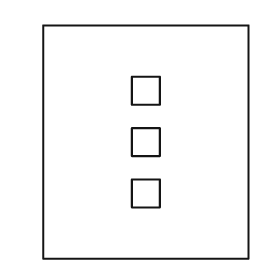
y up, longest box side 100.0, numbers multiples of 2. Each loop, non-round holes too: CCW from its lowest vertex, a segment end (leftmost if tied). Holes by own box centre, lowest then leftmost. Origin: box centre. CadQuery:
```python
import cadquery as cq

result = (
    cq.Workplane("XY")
    .moveTo(-44.0, -50.0)
    .lineTo(44.0, -50.0)
    .lineTo(44.0, 50.0)
    .lineTo(-44.0, 50.0)
    .close()
    .moveTo(-6.0, -28.0)
    .lineTo(6.0, -28.0)
    .lineTo(6.0, -16.0)
    .lineTo(-6.0, -16.0)
    .close()
    .moveTo(-6.0, -6.0)
    .lineTo(6.0, -6.0)
    .lineTo(6.0, 6.0)
    .lineTo(-6.0, 6.0)
    .close()
    .moveTo(-6.0, 16.0)
    .lineTo(6.0, 16.0)
    .lineTo(6.0, 28.0)
    .lineTo(-6.0, 28.0)
    .close()
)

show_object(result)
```